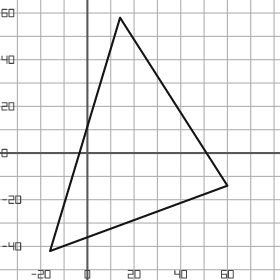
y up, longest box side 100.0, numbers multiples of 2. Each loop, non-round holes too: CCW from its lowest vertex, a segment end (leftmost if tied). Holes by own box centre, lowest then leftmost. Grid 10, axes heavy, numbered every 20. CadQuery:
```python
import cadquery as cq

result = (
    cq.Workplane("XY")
    .moveTo(-16.0, -42.0)
    .lineTo(60.0, -14.0)
    .lineTo(14.0, 58.0)
    .close()
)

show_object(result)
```